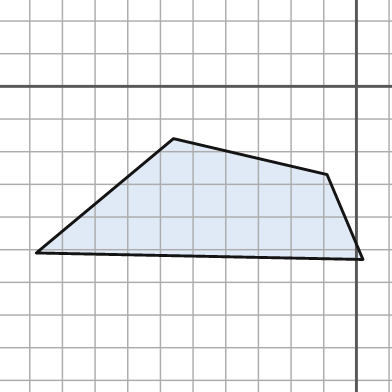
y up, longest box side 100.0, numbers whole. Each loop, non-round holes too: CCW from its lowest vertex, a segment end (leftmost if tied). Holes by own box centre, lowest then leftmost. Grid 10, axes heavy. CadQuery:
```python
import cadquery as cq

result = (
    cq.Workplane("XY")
    .moveTo(2.0, -53.0)
    .lineTo(-9.0, -27.0)
    .lineTo(-56.0, -16.0)
    .lineTo(-98.0, -51.0)
    .close()
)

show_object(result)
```